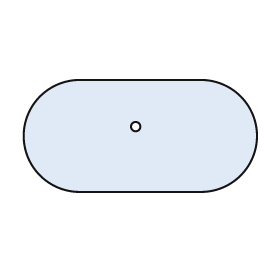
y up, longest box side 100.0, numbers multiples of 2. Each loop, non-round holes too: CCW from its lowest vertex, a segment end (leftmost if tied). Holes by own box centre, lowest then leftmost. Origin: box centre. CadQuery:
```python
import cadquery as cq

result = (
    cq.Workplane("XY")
    .moveTo(-26.0, -24.0)
    .lineTo(26.0, -24.0)
    .threePointArc((50.0, 0.0), (26.0, 24.0))
    .lineTo(-26.0, 24.0)
    .threePointArc((-50.0, 0.0), (-26.0, -24.0))
    .close()
    .moveTo(-2.0, 4.0)
    .circle(2.0)
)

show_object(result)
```